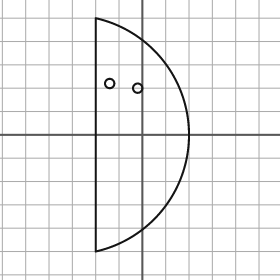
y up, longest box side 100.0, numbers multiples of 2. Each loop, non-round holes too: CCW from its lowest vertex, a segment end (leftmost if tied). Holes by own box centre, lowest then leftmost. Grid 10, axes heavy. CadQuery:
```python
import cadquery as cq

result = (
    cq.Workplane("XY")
    .moveTo(-20.0, -50.0)
    .threePointArc((20.0, 0.0), (-20.0, 50.0))
    .close()
    .moveTo(-2.0, 20.0)
    .circle(2.0)
    .moveTo(-14.0, 22.0)
    .circle(2.0)
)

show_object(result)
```